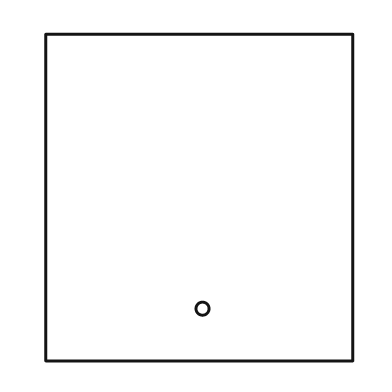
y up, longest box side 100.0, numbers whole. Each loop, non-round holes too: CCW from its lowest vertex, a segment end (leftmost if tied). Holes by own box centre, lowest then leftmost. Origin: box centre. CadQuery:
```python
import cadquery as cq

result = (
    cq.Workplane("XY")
    .moveTo(-47.0, -50.0)
    .lineTo(47.0, -50.0)
    .lineTo(47.0, 50.0)
    .lineTo(-47.0, 50.0)
    .close()
    .moveTo(1.0, -34.0)
    .circle(2.0)
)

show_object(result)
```